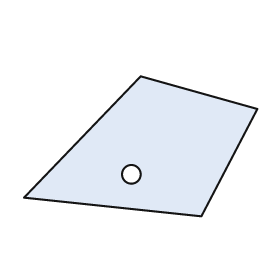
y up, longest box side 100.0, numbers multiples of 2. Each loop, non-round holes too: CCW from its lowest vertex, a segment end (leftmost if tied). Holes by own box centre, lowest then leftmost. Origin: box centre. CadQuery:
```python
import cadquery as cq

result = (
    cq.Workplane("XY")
    .moveTo(26.0, -30.0)
    .lineTo(50.0, 16.0)
    .lineTo(0.0, 30.0)
    .lineTo(-50.0, -22.0)
    .close()
    .moveTo(-4.0, -12.0)
    .circle(4.0)
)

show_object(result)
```